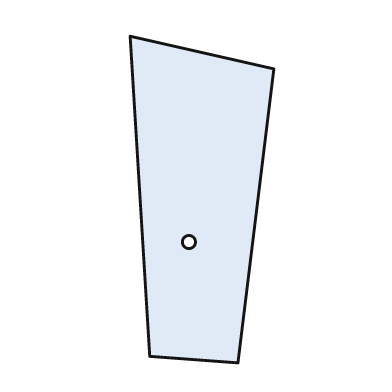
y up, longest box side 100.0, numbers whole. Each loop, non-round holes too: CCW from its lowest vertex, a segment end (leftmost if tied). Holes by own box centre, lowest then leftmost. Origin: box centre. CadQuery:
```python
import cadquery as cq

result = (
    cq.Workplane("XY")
    .moveTo(11.0, -50.0)
    .lineTo(22.0, 40.0)
    .lineTo(-22.0, 50.0)
    .lineTo(-16.0, -48.0)
    .close()
    .moveTo(-4.0, -13.0)
    .circle(2.0)
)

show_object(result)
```